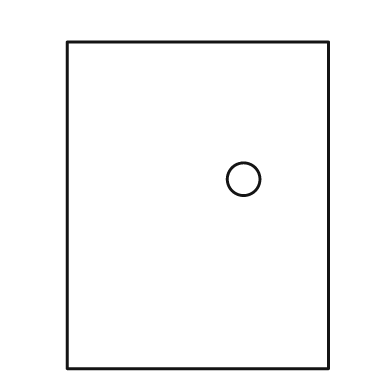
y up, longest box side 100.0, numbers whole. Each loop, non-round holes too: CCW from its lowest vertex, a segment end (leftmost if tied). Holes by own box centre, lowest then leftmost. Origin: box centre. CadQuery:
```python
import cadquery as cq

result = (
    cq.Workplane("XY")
    .moveTo(-40.0, -50.0)
    .lineTo(40.0, -50.0)
    .lineTo(40.0, 50.0)
    .lineTo(-40.0, 50.0)
    .close()
    .moveTo(14.0, 8.0)
    .circle(5.0)
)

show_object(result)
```